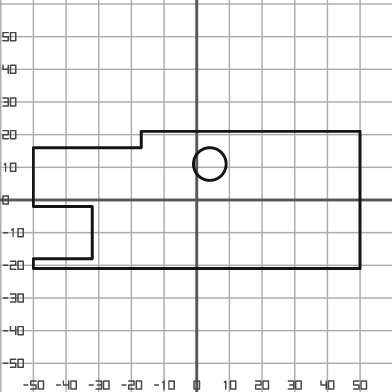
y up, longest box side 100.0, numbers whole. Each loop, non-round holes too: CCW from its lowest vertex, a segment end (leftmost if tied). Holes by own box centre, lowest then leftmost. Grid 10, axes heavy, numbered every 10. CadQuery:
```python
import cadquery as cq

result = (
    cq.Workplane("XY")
    .moveTo(-50.0, -21.0)
    .lineTo(50.0, -21.0)
    .lineTo(50.0, 21.0)
    .lineTo(-17.0, 21.0)
    .lineTo(-17.0, 16.0)
    .lineTo(-50.0, 16.0)
    .lineTo(-50.0, -2.0)
    .lineTo(-32.0, -2.0)
    .lineTo(-32.0, -18.0)
    .lineTo(-50.0, -18.0)
    .close()
    .moveTo(4.0, 11.0)
    .circle(5.0)
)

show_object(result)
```